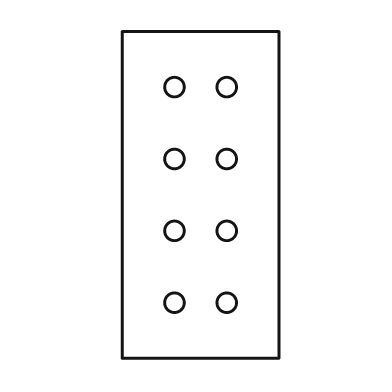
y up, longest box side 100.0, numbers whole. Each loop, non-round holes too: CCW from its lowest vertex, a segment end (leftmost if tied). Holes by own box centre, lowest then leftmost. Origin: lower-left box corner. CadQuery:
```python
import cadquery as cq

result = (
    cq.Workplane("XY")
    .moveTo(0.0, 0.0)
    .lineTo(48.0, 0.0)
    .lineTo(48.0, 100.0)
    .lineTo(0.0, 100.0)
    .close()
    .moveTo(16.0, 17.0)
    .circle(3.0)
    .moveTo(32.0, 17.0)
    .circle(3.0)
    .moveTo(16.0, 39.0)
    .circle(3.0)
    .moveTo(32.0, 39.0)
    .circle(3.0)
    .moveTo(16.0, 61.0)
    .circle(3.0)
    .moveTo(32.0, 61.0)
    .circle(3.0)
    .moveTo(16.0, 83.0)
    .circle(3.0)
    .moveTo(32.0, 83.0)
    .circle(3.0)
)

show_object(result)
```